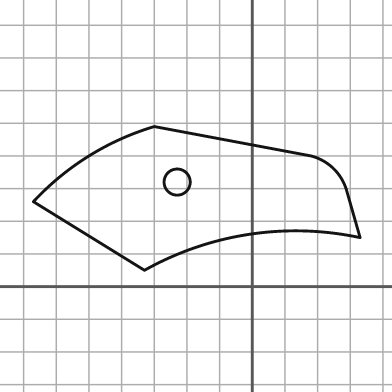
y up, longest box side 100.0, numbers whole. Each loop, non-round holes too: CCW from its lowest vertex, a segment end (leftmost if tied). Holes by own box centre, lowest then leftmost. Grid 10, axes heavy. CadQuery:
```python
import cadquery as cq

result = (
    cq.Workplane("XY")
    .moveTo(-33.0, 5.0)
    .threePointArc((-1.0, 16.0), (33.0, 15.0))
    .lineTo(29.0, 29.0)
    .threePointArc((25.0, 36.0), (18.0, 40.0))
    .lineTo(-30.0, 49.0)
    .threePointArc((-50.0, 40.0), (-67.0, 26.0))
    .close()
    .moveTo(-23.0, 32.0)
    .circle(4.0)
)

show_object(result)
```